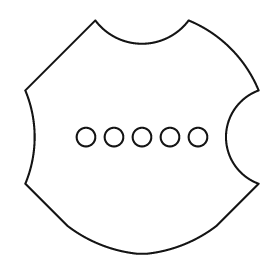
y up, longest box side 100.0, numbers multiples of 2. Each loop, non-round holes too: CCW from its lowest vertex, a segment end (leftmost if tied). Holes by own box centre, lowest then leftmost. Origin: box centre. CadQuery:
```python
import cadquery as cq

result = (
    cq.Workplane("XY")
    .moveTo(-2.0, -50.0)
    .lineTo(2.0, -50.0)
    .threePointArc((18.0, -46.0), (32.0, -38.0))
    .lineTo(50.0, -20.0)
    .threePointArc((36.0, 0.0), (50.0, 20.0))
    .threePointArc((38.0, 38.0), (20.0, 50.0))
    .threePointArc((0.0, 40.0), (-20.0, 50.0))
    .lineTo(-50.0, 20.0)
    .threePointArc((-46.0, 0.0), (-50.0, -20.0))
    .lineTo(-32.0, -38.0)
    .threePointArc((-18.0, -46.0), (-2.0, -50.0))
    .close()
    .moveTo(-24.0, 0.0)
    .circle(4.0)
    .moveTo(-12.0, 0.0)
    .circle(4.0)
    .moveTo(0.0, 0.0)
    .circle(4.0)
    .moveTo(12.0, 0.0)
    .circle(4.0)
    .moveTo(24.0, 0.0)
    .circle(4.0)
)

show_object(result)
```